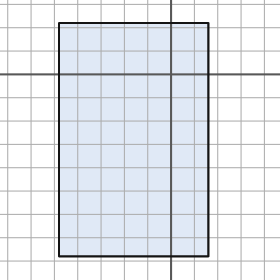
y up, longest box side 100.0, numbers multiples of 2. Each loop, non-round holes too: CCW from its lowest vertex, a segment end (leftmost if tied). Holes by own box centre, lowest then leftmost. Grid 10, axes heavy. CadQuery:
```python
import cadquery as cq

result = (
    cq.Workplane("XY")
    .moveTo(-48.0, -78.0)
    .lineTo(16.0, -78.0)
    .lineTo(16.0, 22.0)
    .lineTo(-48.0, 22.0)
    .close()
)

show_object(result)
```